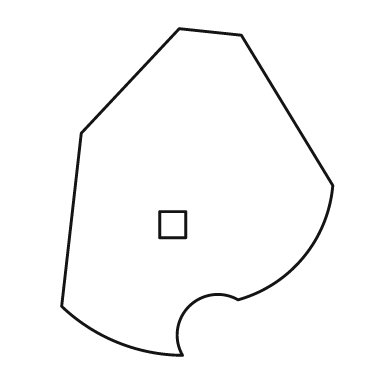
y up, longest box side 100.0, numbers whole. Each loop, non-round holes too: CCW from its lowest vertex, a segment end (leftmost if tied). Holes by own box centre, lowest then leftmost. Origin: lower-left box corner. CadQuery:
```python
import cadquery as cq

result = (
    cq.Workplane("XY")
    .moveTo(37.0, 0.0)
    .threePointArc((39.0, 15.0), (54.0, 17.0))
    .threePointArc((74.0, 30.0), (83.0, 52.0))
    .lineTo(55.0, 98.0)
    .lineTo(36.0, 100.0)
    .lineTo(6.0, 68.0)
    .lineTo(0.0, 15.0)
    .threePointArc((17.0, 4.0), (37.0, 0.0))
    .close()
    .moveTo(30.0, 36.0)
    .lineTo(38.0, 36.0)
    .lineTo(38.0, 44.0)
    .lineTo(30.0, 44.0)
    .close()
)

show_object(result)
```